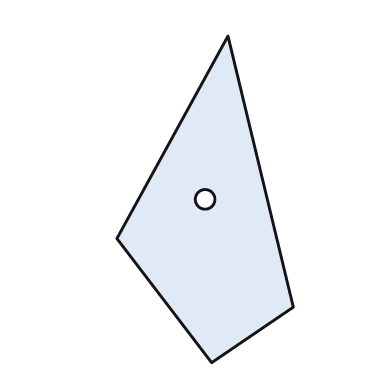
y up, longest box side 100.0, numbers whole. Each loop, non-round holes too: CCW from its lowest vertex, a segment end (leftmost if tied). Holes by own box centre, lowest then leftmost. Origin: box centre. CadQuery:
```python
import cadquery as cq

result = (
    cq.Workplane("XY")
    .moveTo(2.0, -50.0)
    .lineTo(27.0, -33.0)
    .lineTo(7.0, 50.0)
    .lineTo(-27.0, -12.0)
    .close()
    .moveTo(0.0, 0.0)
    .circle(3.0)
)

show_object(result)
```